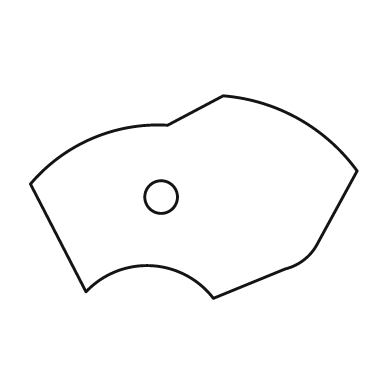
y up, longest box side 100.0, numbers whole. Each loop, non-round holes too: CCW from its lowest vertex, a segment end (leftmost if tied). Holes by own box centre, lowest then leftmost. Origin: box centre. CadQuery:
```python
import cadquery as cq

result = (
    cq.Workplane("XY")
    .moveTo(6.0, -31.0)
    .lineTo(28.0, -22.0)
    .threePointArc((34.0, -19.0), (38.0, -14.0))
    .lineTo(50.0, 8.0)
    .threePointArc((32.0, 24.0), (9.0, 31.0))
    .lineTo(-8.0, 22.0)
    .threePointArc((-31.0, 18.0), (-50.0, 4.0))
    .lineTo(-33.0, -29.0)
    .threePointArc((-13.0, -21.0), (6.0, -31.0))
    .close()
    .moveTo(-10.0, 0.0)
    .circle(5.0)
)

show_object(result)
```